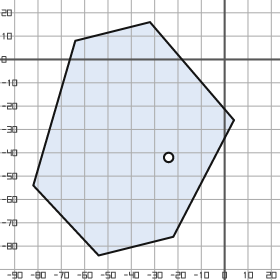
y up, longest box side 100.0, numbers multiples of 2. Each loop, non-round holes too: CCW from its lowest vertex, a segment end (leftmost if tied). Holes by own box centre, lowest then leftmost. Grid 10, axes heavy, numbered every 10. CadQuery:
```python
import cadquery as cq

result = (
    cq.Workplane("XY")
    .moveTo(-54.0, -84.0)
    .lineTo(-22.0, -76.0)
    .lineTo(4.0, -26.0)
    .lineTo(-32.0, 16.0)
    .lineTo(-64.0, 8.0)
    .lineTo(-82.0, -54.0)
    .close()
    .moveTo(-24.0, -42.0)
    .circle(2.0)
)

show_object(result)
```